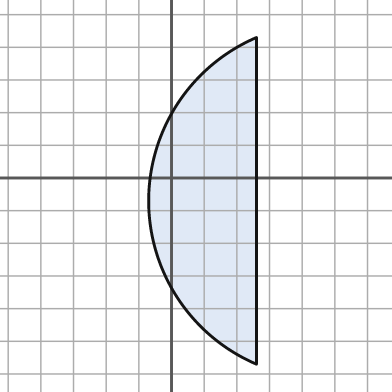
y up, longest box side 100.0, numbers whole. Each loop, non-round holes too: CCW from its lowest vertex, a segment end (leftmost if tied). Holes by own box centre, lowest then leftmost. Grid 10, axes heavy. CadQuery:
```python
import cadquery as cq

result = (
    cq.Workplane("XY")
    .moveTo(26.0, -57.0)
    .lineTo(26.0, 43.0)
    .threePointArc((-7.0, -7.0), (26.0, -57.0))
    .close()
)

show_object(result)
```